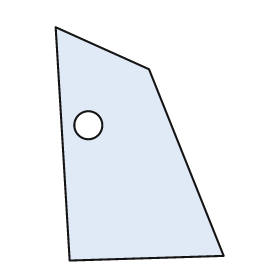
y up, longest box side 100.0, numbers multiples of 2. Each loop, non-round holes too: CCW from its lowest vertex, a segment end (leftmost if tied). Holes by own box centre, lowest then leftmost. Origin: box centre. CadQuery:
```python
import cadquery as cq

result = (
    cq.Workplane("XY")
    .moveTo(-30.0, -50.0)
    .lineTo(36.0, -48.0)
    .lineTo(4.0, 32.0)
    .lineTo(-36.0, 50.0)
    .close()
    .moveTo(-22.0, 8.0)
    .circle(6.0)
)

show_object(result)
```